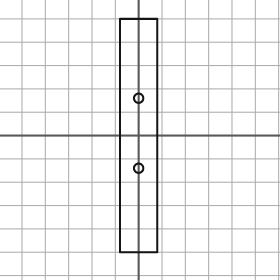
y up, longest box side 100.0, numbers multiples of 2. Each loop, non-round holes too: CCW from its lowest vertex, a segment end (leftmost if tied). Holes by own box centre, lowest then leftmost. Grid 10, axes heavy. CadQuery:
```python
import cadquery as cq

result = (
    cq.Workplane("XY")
    .moveTo(-8.0, -50.0)
    .lineTo(8.0, -50.0)
    .lineTo(8.0, 50.0)
    .lineTo(-8.0, 50.0)
    .close()
    .moveTo(0.0, -14.0)
    .circle(2.0)
    .moveTo(0.0, 16.0)
    .circle(2.0)
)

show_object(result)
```